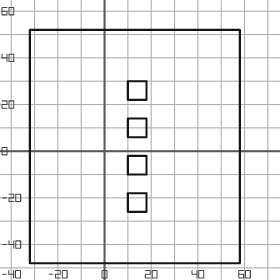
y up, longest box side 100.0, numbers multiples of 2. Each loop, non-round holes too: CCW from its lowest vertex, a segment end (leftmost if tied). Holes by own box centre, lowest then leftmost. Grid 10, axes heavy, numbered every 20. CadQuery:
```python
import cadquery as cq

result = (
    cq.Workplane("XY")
    .moveTo(-32.0, -48.0)
    .lineTo(58.0, -48.0)
    .lineTo(58.0, 52.0)
    .lineTo(-32.0, 52.0)
    .close()
    .moveTo(10.0, -26.0)
    .lineTo(18.0, -26.0)
    .lineTo(18.0, -18.0)
    .lineTo(10.0, -18.0)
    .close()
    .moveTo(10.0, -10.0)
    .lineTo(18.0, -10.0)
    .lineTo(18.0, -2.0)
    .lineTo(10.0, -2.0)
    .close()
    .moveTo(10.0, 6.0)
    .lineTo(18.0, 6.0)
    .lineTo(18.0, 14.0)
    .lineTo(10.0, 14.0)
    .close()
    .moveTo(10.0, 22.0)
    .lineTo(18.0, 22.0)
    .lineTo(18.0, 30.0)
    .lineTo(10.0, 30.0)
    .close()
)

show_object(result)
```